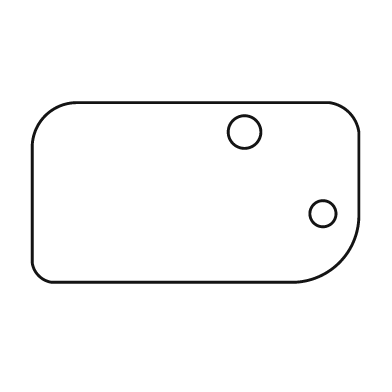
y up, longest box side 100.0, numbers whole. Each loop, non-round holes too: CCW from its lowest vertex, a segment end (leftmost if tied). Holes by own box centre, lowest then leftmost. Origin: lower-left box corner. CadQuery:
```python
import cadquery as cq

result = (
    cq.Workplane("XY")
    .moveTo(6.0, 0.0)
    .lineTo(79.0, 0.0)
    .threePointArc((94.0, 6.0), (100.0, 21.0))
    .lineTo(100.0, 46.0)
    .threePointArc((97.0, 52.0), (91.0, 55.0))
    .lineTo(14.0, 55.0)
    .threePointArc((4.0, 51.0), (0.0, 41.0))
    .lineTo(0.0, 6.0)
    .threePointArc((2.0, 2.0), (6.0, 0.0))
    .close()
    .moveTo(89.0, 21.0)
    .circle(4.0)
    .moveTo(65.0, 46.0)
    .circle(5.0)
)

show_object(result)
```